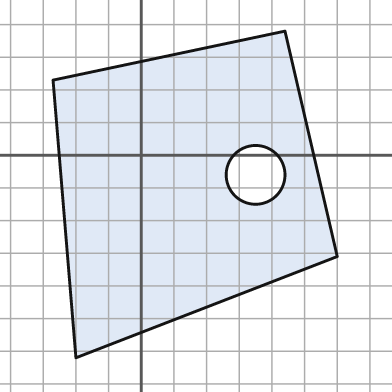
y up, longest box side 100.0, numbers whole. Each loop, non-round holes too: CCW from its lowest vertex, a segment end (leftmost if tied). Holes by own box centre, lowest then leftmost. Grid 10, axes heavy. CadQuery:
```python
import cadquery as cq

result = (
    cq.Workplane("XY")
    .moveTo(-20.0, -62.0)
    .lineTo(60.0, -31.0)
    .lineTo(44.0, 38.0)
    .lineTo(-27.0, 23.0)
    .close()
    .moveTo(35.0, -6.0)
    .circle(9.0)
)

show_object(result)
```